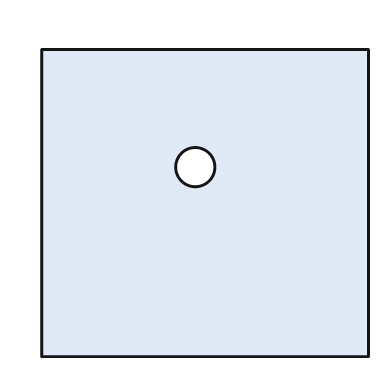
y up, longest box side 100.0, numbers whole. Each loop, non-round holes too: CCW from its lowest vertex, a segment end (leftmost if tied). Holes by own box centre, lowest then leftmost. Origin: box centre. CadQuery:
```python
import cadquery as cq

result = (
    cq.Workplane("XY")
    .moveTo(-50.0, -47.0)
    .lineTo(50.0, -47.0)
    .lineTo(50.0, 47.0)
    .lineTo(-50.0, 47.0)
    .close()
    .moveTo(-3.0, 11.0)
    .circle(6.0)
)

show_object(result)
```